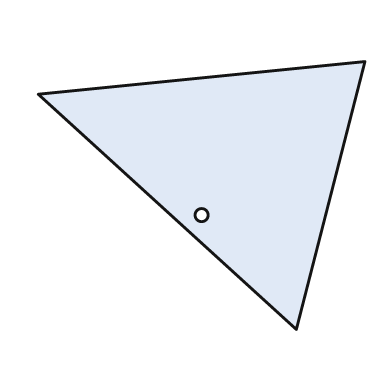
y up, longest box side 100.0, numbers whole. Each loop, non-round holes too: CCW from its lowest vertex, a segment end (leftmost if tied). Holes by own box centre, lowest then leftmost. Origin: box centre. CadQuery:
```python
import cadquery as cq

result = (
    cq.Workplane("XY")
    .moveTo(29.0, -41.0)
    .lineTo(50.0, 41.0)
    .lineTo(-50.0, 31.0)
    .close()
    .moveTo(0.0, -6.0)
    .circle(2.0)
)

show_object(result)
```